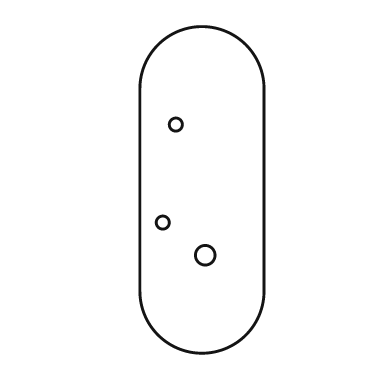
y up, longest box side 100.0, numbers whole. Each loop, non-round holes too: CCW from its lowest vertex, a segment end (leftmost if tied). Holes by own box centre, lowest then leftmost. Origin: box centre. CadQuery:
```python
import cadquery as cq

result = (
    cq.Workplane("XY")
    .moveTo(-19.0, -31.0)
    .threePointArc((0.0, -50.0), (19.0, -31.0))
    .lineTo(19.0, 31.0)
    .threePointArc((0.0, 50.0), (-19.0, 31.0))
    .close()
    .moveTo(1.0, -20.0)
    .circle(3.0)
    .moveTo(-12.0, -10.0)
    .circle(2.0)
    .moveTo(-8.0, 20.0)
    .circle(2.0)
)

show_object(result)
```